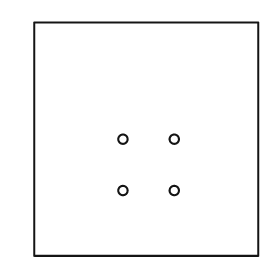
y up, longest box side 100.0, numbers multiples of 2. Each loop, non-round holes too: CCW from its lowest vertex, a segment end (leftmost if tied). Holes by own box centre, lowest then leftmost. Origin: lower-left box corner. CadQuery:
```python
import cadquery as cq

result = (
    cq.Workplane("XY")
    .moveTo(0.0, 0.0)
    .lineTo(96.0, 0.0)
    .lineTo(96.0, 100.0)
    .lineTo(0.0, 100.0)
    .close()
    .moveTo(38.0, 28.0)
    .circle(2.0)
    .moveTo(60.0, 28.0)
    .circle(2.0)
    .moveTo(38.0, 50.0)
    .circle(2.0)
    .moveTo(60.0, 50.0)
    .circle(2.0)
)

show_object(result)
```